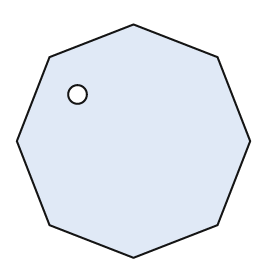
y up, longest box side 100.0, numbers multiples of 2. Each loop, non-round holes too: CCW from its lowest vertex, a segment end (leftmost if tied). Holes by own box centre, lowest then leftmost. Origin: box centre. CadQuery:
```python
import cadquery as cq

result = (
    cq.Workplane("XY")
    .moveTo(0.0, -50.0)
    .lineTo(36.0, -36.0)
    .lineTo(50.0, 0.0)
    .lineTo(36.0, 36.0)
    .lineTo(0.0, 50.0)
    .lineTo(-36.0, 36.0)
    .lineTo(-50.0, 0.0)
    .lineTo(-36.0, -36.0)
    .close()
    .moveTo(-24.0, 20.0)
    .circle(4.0)
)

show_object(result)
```